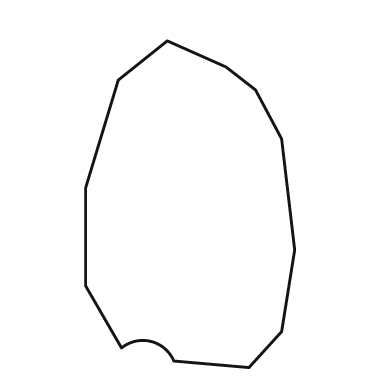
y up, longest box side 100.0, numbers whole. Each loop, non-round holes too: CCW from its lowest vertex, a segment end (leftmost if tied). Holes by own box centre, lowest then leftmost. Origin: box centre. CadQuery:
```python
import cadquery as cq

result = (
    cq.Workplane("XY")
    .moveTo(18.0, -50.0)
    .lineTo(28.0, -39.0)
    .lineTo(32.0, -14.0)
    .lineTo(28.0, 20.0)
    .lineTo(20.0, 35.0)
    .lineTo(11.0, 42.0)
    .lineTo(-7.0, 50.0)
    .lineTo(-22.0, 38.0)
    .lineTo(-32.0, 5.0)
    .lineTo(-32.0, -25.0)
    .lineTo(-21.0, -44.0)
    .threePointArc((-12.0, -42.0), (-5.0, -48.0))
    .close()
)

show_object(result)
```